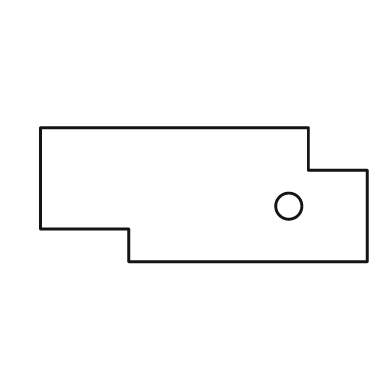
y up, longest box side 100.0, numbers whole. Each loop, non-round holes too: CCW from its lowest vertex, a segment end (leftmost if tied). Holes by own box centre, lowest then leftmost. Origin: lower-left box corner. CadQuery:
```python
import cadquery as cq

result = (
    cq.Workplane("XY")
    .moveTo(27.0, 0.0)
    .lineTo(100.0, 0.0)
    .lineTo(100.0, 28.0)
    .lineTo(82.0, 28.0)
    .lineTo(82.0, 41.0)
    .lineTo(0.0, 41.0)
    .lineTo(0.0, 10.0)
    .lineTo(27.0, 10.0)
    .close()
    .moveTo(76.0, 17.0)
    .circle(4.0)
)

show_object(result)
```